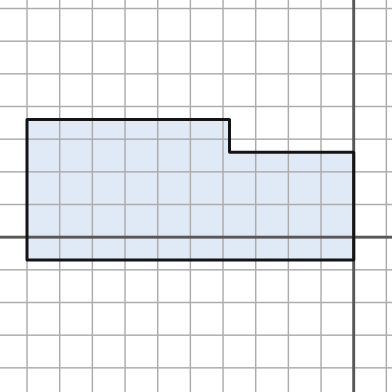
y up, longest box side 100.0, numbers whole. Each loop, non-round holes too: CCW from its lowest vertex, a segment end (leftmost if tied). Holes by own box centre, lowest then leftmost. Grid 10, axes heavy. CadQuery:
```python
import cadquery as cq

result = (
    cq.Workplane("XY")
    .moveTo(-100.0, -7.0)
    .lineTo(0.0, -7.0)
    .lineTo(0.0, 26.0)
    .lineTo(-38.0, 26.0)
    .lineTo(-38.0, 36.0)
    .lineTo(-100.0, 36.0)
    .close()
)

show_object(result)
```